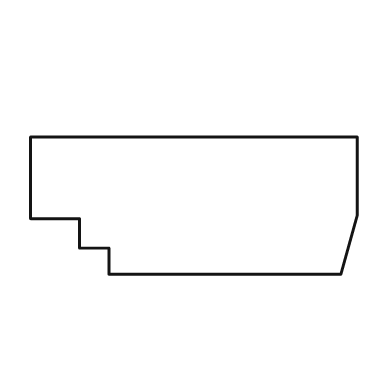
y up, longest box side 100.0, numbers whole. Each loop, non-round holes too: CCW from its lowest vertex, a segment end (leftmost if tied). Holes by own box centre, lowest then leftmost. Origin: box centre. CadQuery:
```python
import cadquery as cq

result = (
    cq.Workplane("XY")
    .moveTo(-26.0, -21.0)
    .lineTo(45.0, -21.0)
    .lineTo(50.0, -3.0)
    .lineTo(50.0, 21.0)
    .lineTo(-50.0, 21.0)
    .lineTo(-50.0, -4.0)
    .lineTo(-35.0, -4.0)
    .lineTo(-35.0, -13.0)
    .lineTo(-26.0, -13.0)
    .close()
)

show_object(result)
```